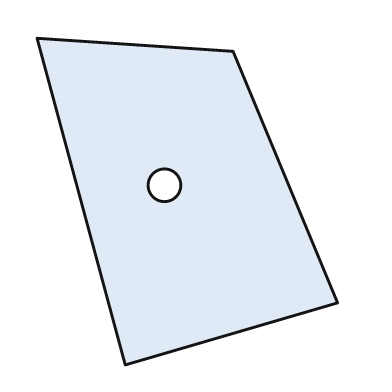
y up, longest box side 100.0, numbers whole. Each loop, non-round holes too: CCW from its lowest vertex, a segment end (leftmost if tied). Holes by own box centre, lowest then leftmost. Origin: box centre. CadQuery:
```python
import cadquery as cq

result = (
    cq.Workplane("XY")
    .moveTo(-19.0, -50.0)
    .lineTo(46.0, -31.0)
    .lineTo(14.0, 46.0)
    .lineTo(-46.0, 50.0)
    .close()
    .moveTo(-7.0, 5.0)
    .circle(5.0)
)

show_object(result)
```